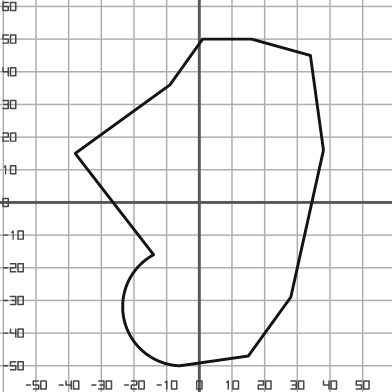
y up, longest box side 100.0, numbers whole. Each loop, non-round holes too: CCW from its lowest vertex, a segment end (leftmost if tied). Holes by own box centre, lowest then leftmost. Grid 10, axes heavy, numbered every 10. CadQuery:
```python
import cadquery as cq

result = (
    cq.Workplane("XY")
    .moveTo(-6.0, -50.0)
    .lineTo(15.0, -47.0)
    .lineTo(28.0, -29.0)
    .lineTo(38.0, 16.0)
    .lineTo(34.0, 45.0)
    .lineTo(16.0, 50.0)
    .lineTo(1.0, 50.0)
    .lineTo(-9.0, 36.0)
    .lineTo(-38.0, 15.0)
    .lineTo(-14.0, -16.0)
    .threePointArc((-23.0, -36.0), (-6.0, -50.0))
    .close()
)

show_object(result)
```